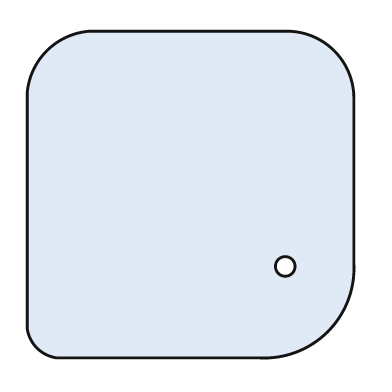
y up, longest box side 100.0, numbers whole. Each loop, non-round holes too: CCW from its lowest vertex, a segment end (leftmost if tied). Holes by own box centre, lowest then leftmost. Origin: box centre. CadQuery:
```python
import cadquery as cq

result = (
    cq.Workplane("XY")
    .moveTo(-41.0, -50.0)
    .lineTo(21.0, -50.0)
    .threePointArc((42.0, -42.0), (50.0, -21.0))
    .lineTo(50.0, 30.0)
    .threePointArc((44.0, 44.0), (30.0, 50.0))
    .lineTo(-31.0, 50.0)
    .threePointArc((-44.0, 44.0), (-50.0, 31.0))
    .lineTo(-50.0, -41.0)
    .threePointArc((-47.0, -47.0), (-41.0, -50.0))
    .close()
    .moveTo(29.0, -22.0)
    .circle(3.0)
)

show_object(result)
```